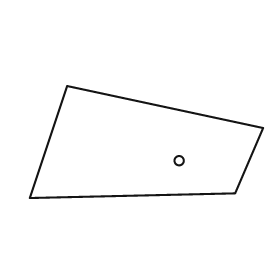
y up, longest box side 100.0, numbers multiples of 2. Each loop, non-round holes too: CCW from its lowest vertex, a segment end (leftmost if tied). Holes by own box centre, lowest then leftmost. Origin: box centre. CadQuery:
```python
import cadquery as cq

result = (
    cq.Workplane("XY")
    .moveTo(-50.0, -24.0)
    .lineTo(38.0, -22.0)
    .lineTo(50.0, 6.0)
    .lineTo(-34.0, 24.0)
    .close()
    .moveTo(14.0, -8.0)
    .circle(2.0)
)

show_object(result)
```